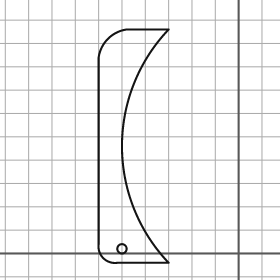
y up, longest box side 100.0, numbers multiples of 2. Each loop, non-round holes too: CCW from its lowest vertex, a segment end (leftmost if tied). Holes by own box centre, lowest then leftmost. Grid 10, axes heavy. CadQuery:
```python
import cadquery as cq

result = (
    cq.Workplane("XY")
    .moveTo(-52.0, -4.0)
    .lineTo(-30.0, -4.0)
    .threePointArc((-50.0, 46.0), (-30.0, 96.0))
    .lineTo(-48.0, 96.0)
    .threePointArc((-56.0, 92.0), (-60.0, 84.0))
    .lineTo(-60.0, 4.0)
    .threePointArc((-58.0, -2.0), (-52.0, -4.0))
    .close()
    .moveTo(-50.0, 2.0)
    .circle(2.0)
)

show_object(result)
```